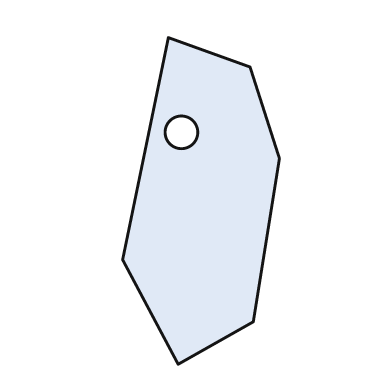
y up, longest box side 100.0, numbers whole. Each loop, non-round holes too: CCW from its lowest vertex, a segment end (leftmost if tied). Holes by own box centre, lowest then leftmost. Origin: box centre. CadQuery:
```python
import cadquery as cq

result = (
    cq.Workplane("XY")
    .moveTo(-7.0, -50.0)
    .lineTo(16.0, -37.0)
    .lineTo(24.0, 13.0)
    .lineTo(15.0, 41.0)
    .lineTo(-10.0, 50.0)
    .lineTo(-24.0, -18.0)
    .close()
    .moveTo(-6.0, 21.0)
    .circle(5.0)
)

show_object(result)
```